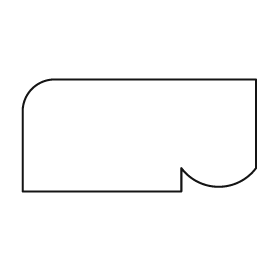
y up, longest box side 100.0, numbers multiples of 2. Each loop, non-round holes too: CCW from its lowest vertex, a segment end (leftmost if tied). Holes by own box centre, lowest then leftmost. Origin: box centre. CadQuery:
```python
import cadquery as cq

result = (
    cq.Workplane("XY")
    .moveTo(-50.0, -24.0)
    .lineTo(18.0, -24.0)
    .lineTo(18.0, -14.0)
    .threePointArc((34.0, -22.0), (50.0, -14.0))
    .lineTo(50.0, 24.0)
    .lineTo(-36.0, 24.0)
    .threePointArc((-46.0, 20.0), (-50.0, 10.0))
    .close()
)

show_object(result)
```